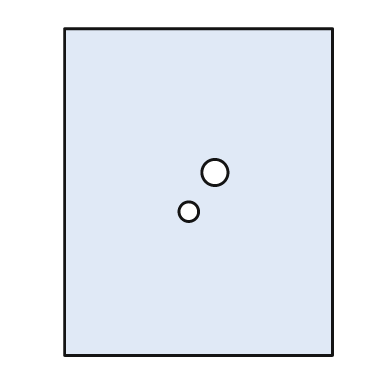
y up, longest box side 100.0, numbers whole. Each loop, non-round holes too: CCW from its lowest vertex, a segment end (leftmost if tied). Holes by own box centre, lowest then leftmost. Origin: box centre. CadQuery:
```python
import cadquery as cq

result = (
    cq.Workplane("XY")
    .moveTo(-41.0, -50.0)
    .lineTo(41.0, -50.0)
    .lineTo(41.0, 50.0)
    .lineTo(-41.0, 50.0)
    .close()
    .moveTo(-3.0, -6.0)
    .circle(3.0)
    .moveTo(5.0, 6.0)
    .circle(4.0)
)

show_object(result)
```